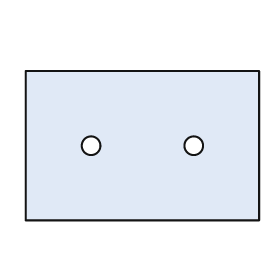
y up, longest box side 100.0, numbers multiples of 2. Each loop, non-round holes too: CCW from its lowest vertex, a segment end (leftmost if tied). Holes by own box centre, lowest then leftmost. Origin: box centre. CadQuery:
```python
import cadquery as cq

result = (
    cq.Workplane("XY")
    .moveTo(-50.0, -32.0)
    .lineTo(50.0, -32.0)
    .lineTo(50.0, 32.0)
    .lineTo(-50.0, 32.0)
    .close()
    .moveTo(-22.0, 0.0)
    .circle(4.0)
    .moveTo(22.0, 0.0)
    .circle(4.0)
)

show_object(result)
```